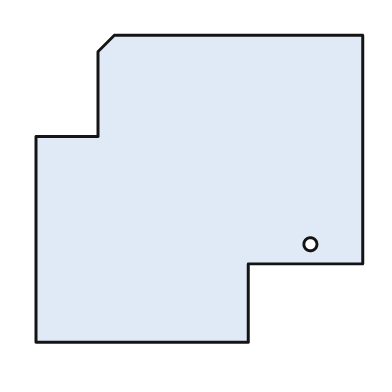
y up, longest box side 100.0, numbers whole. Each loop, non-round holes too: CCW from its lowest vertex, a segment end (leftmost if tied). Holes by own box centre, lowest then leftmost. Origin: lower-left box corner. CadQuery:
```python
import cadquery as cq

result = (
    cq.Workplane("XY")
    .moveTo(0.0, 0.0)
    .lineTo(65.0, 0.0)
    .lineTo(65.0, 24.0)
    .lineTo(100.0, 24.0)
    .lineTo(100.0, 94.0)
    .lineTo(24.0, 94.0)
    .lineTo(19.0, 89.0)
    .lineTo(19.0, 63.0)
    .lineTo(0.0, 63.0)
    .close()
    .moveTo(84.0, 30.0)
    .circle(2.0)
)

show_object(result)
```